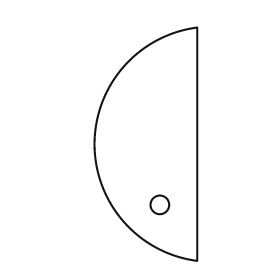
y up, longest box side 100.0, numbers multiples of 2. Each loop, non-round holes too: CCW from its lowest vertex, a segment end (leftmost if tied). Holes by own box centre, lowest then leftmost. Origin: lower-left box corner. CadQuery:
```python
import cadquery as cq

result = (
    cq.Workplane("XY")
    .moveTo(44.0, 0.0)
    .lineTo(44.0, 100.0)
    .threePointArc((0.0, 50.0), (44.0, 0.0))
    .close()
    .moveTo(28.0, 24.0)
    .circle(4.0)
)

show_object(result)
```